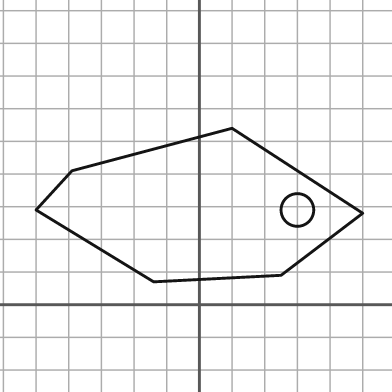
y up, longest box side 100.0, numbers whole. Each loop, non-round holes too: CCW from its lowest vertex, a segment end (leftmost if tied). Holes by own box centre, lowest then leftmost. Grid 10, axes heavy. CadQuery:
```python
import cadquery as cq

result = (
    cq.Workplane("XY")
    .moveTo(-14.0, 7.0)
    .lineTo(25.0, 9.0)
    .lineTo(50.0, 28.0)
    .lineTo(10.0, 54.0)
    .lineTo(-39.0, 41.0)
    .lineTo(-50.0, 29.0)
    .close()
    .moveTo(30.0, 29.0)
    .circle(5.0)
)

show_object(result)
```